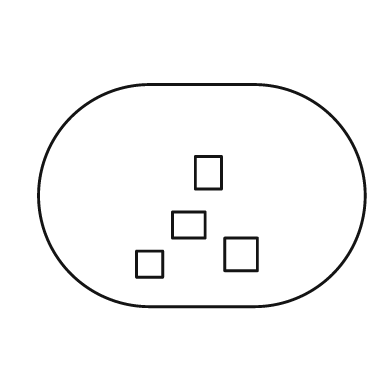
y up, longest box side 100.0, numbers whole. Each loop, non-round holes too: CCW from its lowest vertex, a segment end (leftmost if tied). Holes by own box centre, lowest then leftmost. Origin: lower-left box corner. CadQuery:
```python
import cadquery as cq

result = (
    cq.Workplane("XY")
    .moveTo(34.0, 0.0)
    .lineTo(66.0, 0.0)
    .threePointArc((100.0, 34.0), (66.0, 68.0))
    .lineTo(34.0, 68.0)
    .threePointArc((0.0, 34.0), (34.0, 0.0))
    .close()
    .moveTo(30.0, 9.0)
    .lineTo(38.0, 9.0)
    .lineTo(38.0, 17.0)
    .lineTo(30.0, 17.0)
    .close()
    .moveTo(57.0, 11.0)
    .lineTo(67.0, 11.0)
    .lineTo(67.0, 21.0)
    .lineTo(57.0, 21.0)
    .close()
    .moveTo(41.0, 21.0)
    .lineTo(51.0, 21.0)
    .lineTo(51.0, 29.0)
    .lineTo(41.0, 29.0)
    .close()
    .moveTo(48.0, 36.0)
    .lineTo(56.0, 36.0)
    .lineTo(56.0, 46.0)
    .lineTo(48.0, 46.0)
    .close()
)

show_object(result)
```